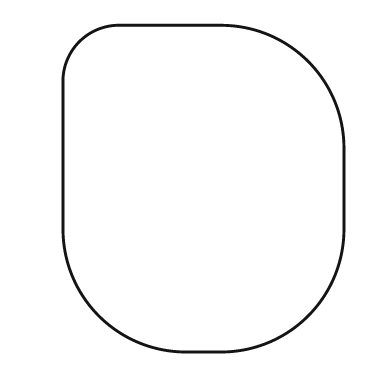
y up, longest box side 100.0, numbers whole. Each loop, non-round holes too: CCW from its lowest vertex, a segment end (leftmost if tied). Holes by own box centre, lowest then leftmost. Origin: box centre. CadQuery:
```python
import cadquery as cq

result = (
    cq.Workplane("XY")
    .moveTo(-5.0, -50.0)
    .lineTo(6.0, -50.0)
    .threePointArc((32.0, -39.0), (43.0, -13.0))
    .lineTo(43.0, 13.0)
    .threePointArc((32.0, 39.0), (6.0, 50.0))
    .lineTo(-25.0, 50.0)
    .threePointArc((-38.0, 45.0), (-43.0, 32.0))
    .lineTo(-43.0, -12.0)
    .threePointArc((-32.0, -39.0), (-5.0, -50.0))
    .close()
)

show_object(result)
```